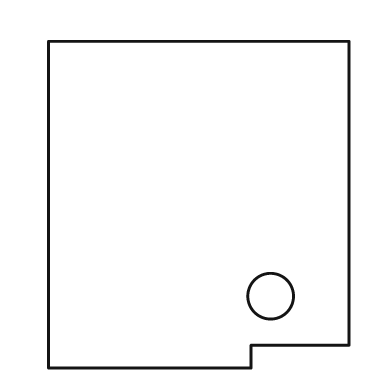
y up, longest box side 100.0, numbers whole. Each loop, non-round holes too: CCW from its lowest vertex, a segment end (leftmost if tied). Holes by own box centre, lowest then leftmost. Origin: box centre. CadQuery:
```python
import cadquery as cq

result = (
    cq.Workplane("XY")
    .moveTo(-46.0, -50.0)
    .lineTo(16.0, -50.0)
    .lineTo(16.0, -43.0)
    .lineTo(46.0, -43.0)
    .lineTo(46.0, 50.0)
    .lineTo(-46.0, 50.0)
    .close()
    .moveTo(22.0, -28.0)
    .circle(7.0)
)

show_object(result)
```